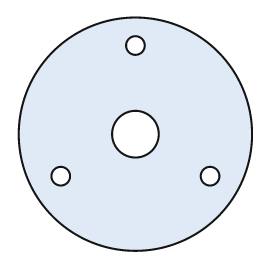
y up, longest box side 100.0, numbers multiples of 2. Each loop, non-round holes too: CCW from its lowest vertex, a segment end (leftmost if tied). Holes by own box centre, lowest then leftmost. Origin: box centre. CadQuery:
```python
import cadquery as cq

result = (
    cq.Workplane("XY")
    .moveTo(0.0, 0.0)
    .circle(50.0)
    .moveTo(-32.0, -18.0)
    .circle(4.0)
    .moveTo(32.0, -18.0)
    .circle(4.0)
    .moveTo(0.0, 0.0)
    .circle(10.0)
    .moveTo(0.0, 38.0)
    .circle(4.0)
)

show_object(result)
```